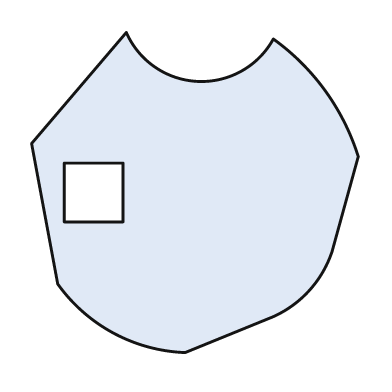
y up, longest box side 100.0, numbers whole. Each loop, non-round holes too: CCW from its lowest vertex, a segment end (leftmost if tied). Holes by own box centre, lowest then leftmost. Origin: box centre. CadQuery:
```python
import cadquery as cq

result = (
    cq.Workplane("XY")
    .moveTo(-3.0, -49.0)
    .lineTo(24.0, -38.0)
    .threePointArc((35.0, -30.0), (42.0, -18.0))
    .lineTo(50.0, 11.0)
    .threePointArc((40.0, 31.0), (24.0, 47.0))
    .threePointArc((1.0, 34.0), (-21.0, 49.0))
    .lineTo(-50.0, 15.0)
    .lineTo(-42.0, -28.0)
    .threePointArc((-25.0, -43.0), (-3.0, -49.0))
    .close()
    .moveTo(-40.0, -9.0)
    .lineTo(-22.0, -9.0)
    .lineTo(-22.0, 9.0)
    .lineTo(-40.0, 9.0)
    .close()
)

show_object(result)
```